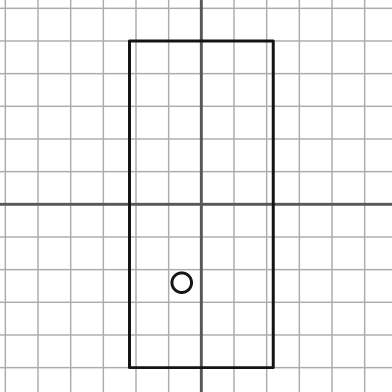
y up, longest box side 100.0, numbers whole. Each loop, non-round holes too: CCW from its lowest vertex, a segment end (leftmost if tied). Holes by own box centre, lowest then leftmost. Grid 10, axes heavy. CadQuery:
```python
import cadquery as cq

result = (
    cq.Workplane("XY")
    .moveTo(-22.0, -50.0)
    .lineTo(22.0, -50.0)
    .lineTo(22.0, 50.0)
    .lineTo(-22.0, 50.0)
    .close()
    .moveTo(-6.0, -24.0)
    .circle(3.0)
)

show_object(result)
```